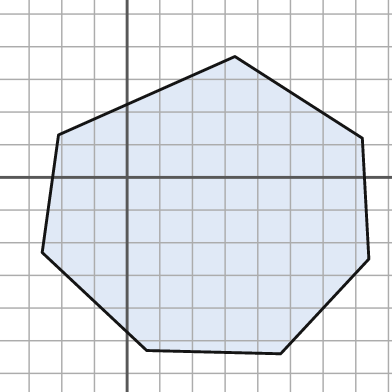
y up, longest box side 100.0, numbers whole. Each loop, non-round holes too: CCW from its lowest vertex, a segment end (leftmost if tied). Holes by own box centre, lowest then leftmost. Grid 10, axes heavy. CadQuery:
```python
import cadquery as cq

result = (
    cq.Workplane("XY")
    .moveTo(47.0, -54.0)
    .lineTo(74.0, -25.0)
    .lineTo(72.0, 12.0)
    .lineTo(33.0, 37.0)
    .lineTo(-21.0, 13.0)
    .lineTo(-26.0, -23.0)
    .lineTo(6.0, -53.0)
    .close()
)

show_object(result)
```